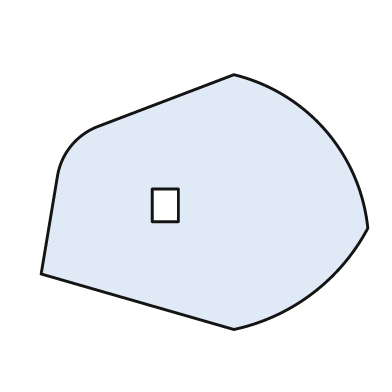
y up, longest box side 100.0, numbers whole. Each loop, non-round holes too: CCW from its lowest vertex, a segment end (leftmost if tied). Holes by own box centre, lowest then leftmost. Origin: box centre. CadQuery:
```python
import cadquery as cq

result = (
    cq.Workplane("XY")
    .moveTo(9.0, -39.0)
    .threePointArc((33.0, -28.0), (50.0, -8.0))
    .threePointArc((37.0, 22.0), (9.0, 39.0))
    .lineTo(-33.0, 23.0)
    .threePointArc((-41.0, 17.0), (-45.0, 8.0))
    .lineTo(-50.0, -22.0)
    .close()
    .moveTo(-16.0, -6.0)
    .lineTo(-8.0, -6.0)
    .lineTo(-8.0, 4.0)
    .lineTo(-16.0, 4.0)
    .close()
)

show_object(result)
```